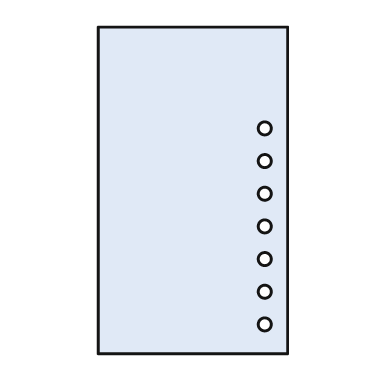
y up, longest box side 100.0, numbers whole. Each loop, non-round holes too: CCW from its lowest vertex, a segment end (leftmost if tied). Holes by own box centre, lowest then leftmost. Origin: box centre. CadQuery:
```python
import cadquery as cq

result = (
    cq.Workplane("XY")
    .moveTo(-29.0, -50.0)
    .lineTo(29.0, -50.0)
    .lineTo(29.0, 50.0)
    .lineTo(-29.0, 50.0)
    .close()
    .moveTo(22.0, -41.0)
    .circle(2.0)
    .moveTo(22.0, -31.0)
    .circle(2.0)
    .moveTo(22.0, -21.0)
    .circle(2.0)
    .moveTo(22.0, -11.0)
    .circle(2.0)
    .moveTo(22.0, -1.0)
    .circle(2.0)
    .moveTo(22.0, 9.0)
    .circle(2.0)
    .moveTo(22.0, 19.0)
    .circle(2.0)
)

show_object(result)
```